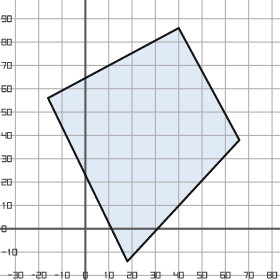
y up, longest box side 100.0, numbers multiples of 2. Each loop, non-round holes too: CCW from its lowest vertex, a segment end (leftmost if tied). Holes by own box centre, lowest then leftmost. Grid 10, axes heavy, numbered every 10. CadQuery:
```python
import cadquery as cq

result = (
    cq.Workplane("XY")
    .moveTo(18.0, -14.0)
    .lineTo(66.0, 38.0)
    .lineTo(40.0, 86.0)
    .lineTo(-16.0, 56.0)
    .close()
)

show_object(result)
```